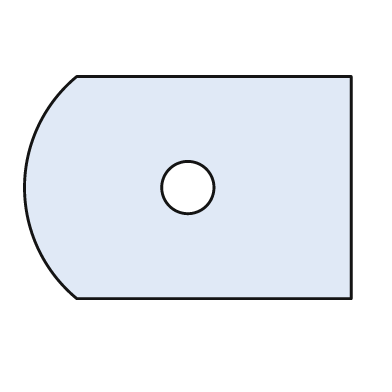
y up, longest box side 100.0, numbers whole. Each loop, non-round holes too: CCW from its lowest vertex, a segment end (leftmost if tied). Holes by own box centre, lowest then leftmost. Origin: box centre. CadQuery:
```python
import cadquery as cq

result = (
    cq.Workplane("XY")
    .moveTo(-34.0, -34.0)
    .lineTo(50.0, -34.0)
    .lineTo(50.0, 34.0)
    .lineTo(-34.0, 34.0)
    .threePointArc((-50.0, 0.0), (-34.0, -34.0))
    .close()
    .moveTo(0.0, 0.0)
    .circle(8.0)
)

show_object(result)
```